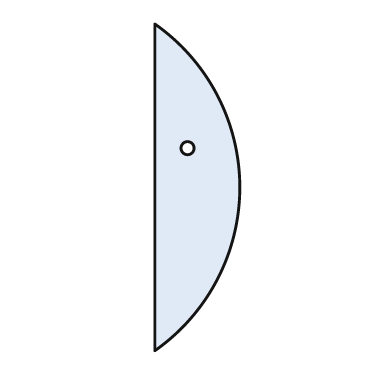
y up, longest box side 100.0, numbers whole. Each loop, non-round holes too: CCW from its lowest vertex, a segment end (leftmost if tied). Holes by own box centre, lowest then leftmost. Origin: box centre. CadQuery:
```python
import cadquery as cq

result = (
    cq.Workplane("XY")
    .moveTo(-13.0, -50.0)
    .threePointArc((13.0, 0.0), (-13.0, 50.0))
    .close()
    .moveTo(-3.0, 12.0)
    .circle(2.0)
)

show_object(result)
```